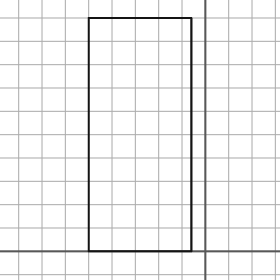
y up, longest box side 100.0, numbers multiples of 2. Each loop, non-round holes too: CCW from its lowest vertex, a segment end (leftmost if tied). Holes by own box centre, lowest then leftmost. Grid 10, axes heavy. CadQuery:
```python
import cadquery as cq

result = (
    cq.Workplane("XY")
    .moveTo(-50.0, 0.0)
    .lineTo(-6.0, 0.0)
    .lineTo(-6.0, 100.0)
    .lineTo(-50.0, 100.0)
    .close()
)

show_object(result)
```